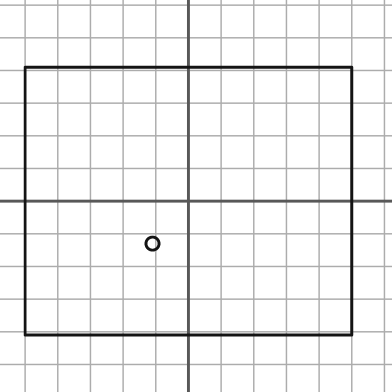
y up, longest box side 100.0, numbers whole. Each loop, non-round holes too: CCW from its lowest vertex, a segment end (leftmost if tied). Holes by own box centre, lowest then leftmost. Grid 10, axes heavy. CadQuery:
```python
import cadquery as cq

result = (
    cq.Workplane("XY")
    .moveTo(-50.0, -41.0)
    .lineTo(50.0, -41.0)
    .lineTo(50.0, 41.0)
    .lineTo(-50.0, 41.0)
    .close()
    .moveTo(-11.0, -13.0)
    .circle(2.0)
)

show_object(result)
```